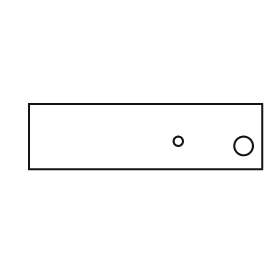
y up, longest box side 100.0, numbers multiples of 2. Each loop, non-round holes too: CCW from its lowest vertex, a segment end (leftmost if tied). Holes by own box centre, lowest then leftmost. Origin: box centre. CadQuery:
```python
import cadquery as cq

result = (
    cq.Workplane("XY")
    .moveTo(-50.0, -14.0)
    .lineTo(50.0, -14.0)
    .lineTo(50.0, 14.0)
    .lineTo(-50.0, 14.0)
    .close()
    .moveTo(42.0, -4.0)
    .circle(4.0)
    .moveTo(14.0, -2.0)
    .circle(2.0)
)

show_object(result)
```